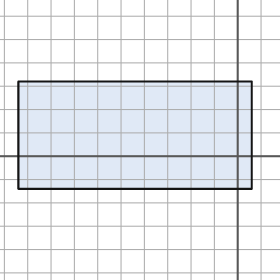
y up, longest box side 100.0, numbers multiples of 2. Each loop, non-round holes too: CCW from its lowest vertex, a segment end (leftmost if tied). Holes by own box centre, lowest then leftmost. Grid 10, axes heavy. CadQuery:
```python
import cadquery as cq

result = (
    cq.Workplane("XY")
    .moveTo(-94.0, -14.0)
    .lineTo(6.0, -14.0)
    .lineTo(6.0, 32.0)
    .lineTo(-94.0, 32.0)
    .close()
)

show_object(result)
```